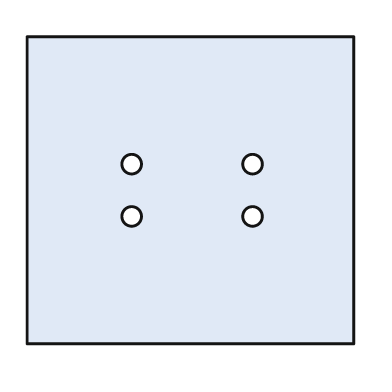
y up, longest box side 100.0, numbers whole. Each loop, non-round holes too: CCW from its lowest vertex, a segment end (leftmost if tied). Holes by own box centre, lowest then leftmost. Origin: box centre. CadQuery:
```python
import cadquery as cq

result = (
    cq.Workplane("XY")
    .moveTo(-50.0, -47.0)
    .lineTo(50.0, -47.0)
    .lineTo(50.0, 47.0)
    .lineTo(-50.0, 47.0)
    .close()
    .moveTo(-18.0, -8.0)
    .circle(3.0)
    .moveTo(19.0, -8.0)
    .circle(3.0)
    .moveTo(-18.0, 8.0)
    .circle(3.0)
    .moveTo(19.0, 8.0)
    .circle(3.0)
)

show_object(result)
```